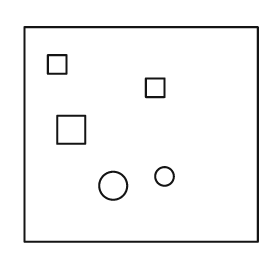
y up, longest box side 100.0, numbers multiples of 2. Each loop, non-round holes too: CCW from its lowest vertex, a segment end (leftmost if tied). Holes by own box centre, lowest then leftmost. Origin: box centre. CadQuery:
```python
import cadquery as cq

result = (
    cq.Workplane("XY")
    .moveTo(-50.0, -46.0)
    .lineTo(50.0, -46.0)
    .lineTo(50.0, 46.0)
    .lineTo(-50.0, 46.0)
    .close()
    .moveTo(-12.0, -22.0)
    .circle(6.0)
    .moveTo(10.0, -18.0)
    .circle(4.0)
    .moveTo(-36.0, -4.0)
    .lineTo(-24.0, -4.0)
    .lineTo(-24.0, 8.0)
    .lineTo(-36.0, 8.0)
    .close()
    .moveTo(2.0, 16.0)
    .lineTo(10.0, 16.0)
    .lineTo(10.0, 24.0)
    .lineTo(2.0, 24.0)
    .close()
    .moveTo(-40.0, 26.0)
    .lineTo(-32.0, 26.0)
    .lineTo(-32.0, 34.0)
    .lineTo(-40.0, 34.0)
    .close()
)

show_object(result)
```